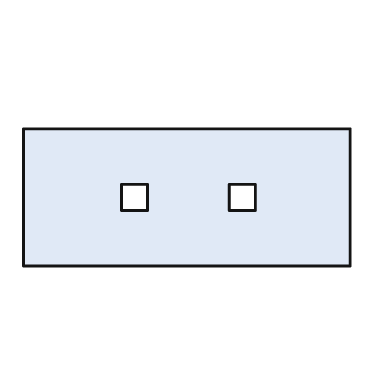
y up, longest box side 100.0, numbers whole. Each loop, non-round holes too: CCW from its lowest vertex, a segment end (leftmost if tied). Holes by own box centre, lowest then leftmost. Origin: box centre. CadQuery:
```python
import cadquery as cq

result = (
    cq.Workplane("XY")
    .moveTo(-50.0, -21.0)
    .lineTo(50.0, -21.0)
    .lineTo(50.0, 21.0)
    .lineTo(-50.0, 21.0)
    .close()
    .moveTo(-20.0, -4.0)
    .lineTo(-12.0, -4.0)
    .lineTo(-12.0, 4.0)
    .lineTo(-20.0, 4.0)
    .close()
    .moveTo(13.0, -4.0)
    .lineTo(21.0, -4.0)
    .lineTo(21.0, 4.0)
    .lineTo(13.0, 4.0)
    .close()
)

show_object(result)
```